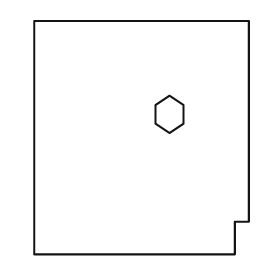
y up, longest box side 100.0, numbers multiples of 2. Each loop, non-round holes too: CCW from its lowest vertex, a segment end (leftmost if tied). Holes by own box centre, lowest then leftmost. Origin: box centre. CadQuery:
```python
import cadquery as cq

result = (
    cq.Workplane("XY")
    .moveTo(-46.0, -50.0)
    .lineTo(40.0, -50.0)
    .lineTo(40.0, -36.0)
    .lineTo(46.0, -36.0)
    .lineTo(46.0, 50.0)
    .lineTo(-46.0, 50.0)
    .close()
    .moveTo(12.0, 2.0)
    .lineTo(18.0, 6.0)
    .lineTo(18.0, 14.0)
    .lineTo(12.0, 18.0)
    .lineTo(6.0, 14.0)
    .lineTo(6.0, 6.0)
    .close()
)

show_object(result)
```